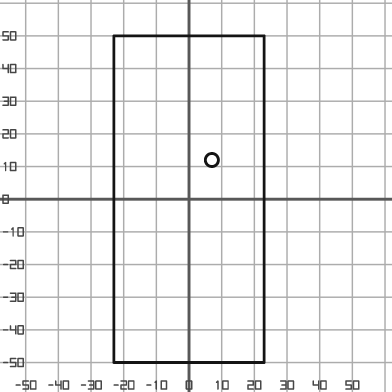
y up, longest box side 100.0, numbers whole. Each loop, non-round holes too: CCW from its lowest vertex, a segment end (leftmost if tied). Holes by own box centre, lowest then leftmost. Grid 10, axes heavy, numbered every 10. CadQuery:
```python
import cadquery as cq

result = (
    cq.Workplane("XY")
    .moveTo(-23.0, -50.0)
    .lineTo(23.0, -50.0)
    .lineTo(23.0, 50.0)
    .lineTo(-23.0, 50.0)
    .close()
    .moveTo(7.0, 12.0)
    .circle(2.0)
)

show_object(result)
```